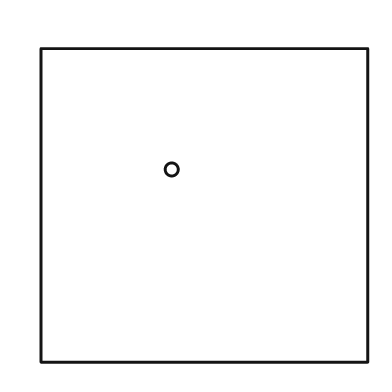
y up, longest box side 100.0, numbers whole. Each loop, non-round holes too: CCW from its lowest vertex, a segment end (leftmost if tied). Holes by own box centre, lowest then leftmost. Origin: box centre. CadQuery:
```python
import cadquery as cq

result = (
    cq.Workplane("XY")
    .moveTo(-50.0, -48.0)
    .lineTo(50.0, -48.0)
    .lineTo(50.0, 48.0)
    .lineTo(-50.0, 48.0)
    .close()
    .moveTo(-10.0, 11.0)
    .circle(2.0)
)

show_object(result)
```